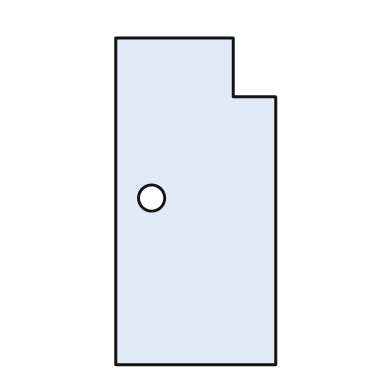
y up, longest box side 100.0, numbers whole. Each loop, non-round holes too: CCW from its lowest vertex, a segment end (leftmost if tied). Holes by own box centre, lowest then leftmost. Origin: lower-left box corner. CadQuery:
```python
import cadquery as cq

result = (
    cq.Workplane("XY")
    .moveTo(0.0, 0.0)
    .lineTo(49.0, 0.0)
    .lineTo(49.0, 82.0)
    .lineTo(36.0, 82.0)
    .lineTo(36.0, 100.0)
    .lineTo(0.0, 100.0)
    .close()
    .moveTo(11.0, 51.0)
    .circle(4.0)
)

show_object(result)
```